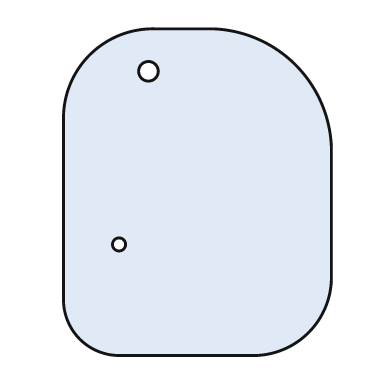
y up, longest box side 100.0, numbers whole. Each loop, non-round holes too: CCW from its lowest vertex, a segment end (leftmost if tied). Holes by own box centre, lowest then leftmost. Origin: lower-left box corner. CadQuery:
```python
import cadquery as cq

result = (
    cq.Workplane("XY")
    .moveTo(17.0, 0.0)
    .lineTo(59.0, 0.0)
    .threePointArc((75.0, 7.0), (82.0, 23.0))
    .lineTo(82.0, 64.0)
    .threePointArc((71.0, 89.0), (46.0, 100.0))
    .lineTo(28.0, 100.0)
    .threePointArc((8.0, 92.0), (0.0, 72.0))
    .lineTo(0.0, 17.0)
    .threePointArc((5.0, 5.0), (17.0, 0.0))
    .close()
    .moveTo(17.0, 34.0)
    .circle(2.0)
    .moveTo(26.0, 87.0)
    .circle(3.0)
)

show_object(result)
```